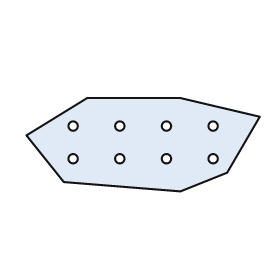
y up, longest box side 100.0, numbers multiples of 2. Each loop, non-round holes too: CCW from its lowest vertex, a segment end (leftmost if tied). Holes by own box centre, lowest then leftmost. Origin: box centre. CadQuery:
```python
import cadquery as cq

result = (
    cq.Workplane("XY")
    .moveTo(16.0, -20.0)
    .lineTo(36.0, -12.0)
    .lineTo(50.0, 12.0)
    .lineTo(16.0, 20.0)
    .lineTo(-24.0, 20.0)
    .lineTo(-50.0, 4.0)
    .lineTo(-34.0, -16.0)
    .close()
    .moveTo(-30.0, -6.0)
    .circle(2.0)
    .moveTo(-10.0, -6.0)
    .circle(2.0)
    .moveTo(10.0, -6.0)
    .circle(2.0)
    .moveTo(30.0, -6.0)
    .circle(2.0)
    .moveTo(-30.0, 8.0)
    .circle(2.0)
    .moveTo(-10.0, 8.0)
    .circle(2.0)
    .moveTo(10.0, 8.0)
    .circle(2.0)
    .moveTo(30.0, 8.0)
    .circle(2.0)
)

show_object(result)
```